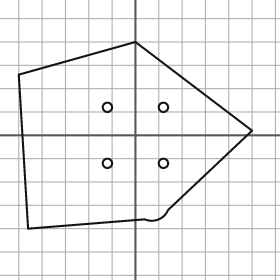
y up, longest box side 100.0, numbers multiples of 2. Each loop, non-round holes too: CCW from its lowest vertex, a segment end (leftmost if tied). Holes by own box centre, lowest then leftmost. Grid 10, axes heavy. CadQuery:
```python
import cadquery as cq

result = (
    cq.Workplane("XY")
    .moveTo(-46.0, -40.0)
    .lineTo(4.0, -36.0)
    .threePointArc((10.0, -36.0), (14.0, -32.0))
    .lineTo(50.0, 2.0)
    .lineTo(0.0, 40.0)
    .lineTo(-50.0, 26.0)
    .close()
    .moveTo(-12.0, -12.0)
    .circle(2.0)
    .moveTo(12.0, -12.0)
    .circle(2.0)
    .moveTo(-12.0, 12.0)
    .circle(2.0)
    .moveTo(12.0, 12.0)
    .circle(2.0)
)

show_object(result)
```